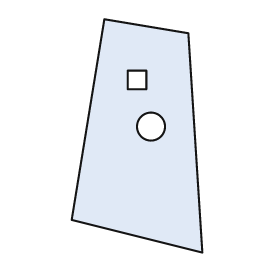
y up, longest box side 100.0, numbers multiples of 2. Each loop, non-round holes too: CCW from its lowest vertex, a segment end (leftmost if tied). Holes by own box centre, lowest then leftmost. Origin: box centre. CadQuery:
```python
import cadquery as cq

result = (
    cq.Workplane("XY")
    .moveTo(28.0, -50.0)
    .lineTo(22.0, 44.0)
    .lineTo(-14.0, 50.0)
    .lineTo(-28.0, -36.0)
    .close()
    .moveTo(6.0, 4.0)
    .circle(6.0)
    .moveTo(-4.0, 20.0)
    .lineTo(4.0, 20.0)
    .lineTo(4.0, 28.0)
    .lineTo(-4.0, 28.0)
    .close()
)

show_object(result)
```